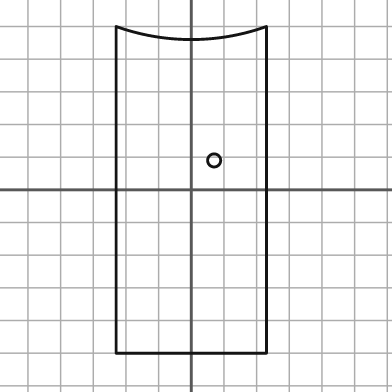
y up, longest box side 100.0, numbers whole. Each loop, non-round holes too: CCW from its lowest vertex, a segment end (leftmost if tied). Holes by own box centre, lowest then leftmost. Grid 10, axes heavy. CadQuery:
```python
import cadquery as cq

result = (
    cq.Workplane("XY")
    .moveTo(-23.0, -50.0)
    .lineTo(23.0, -50.0)
    .lineTo(23.0, 50.0)
    .threePointArc((0.0, 46.0), (-23.0, 50.0))
    .close()
    .moveTo(7.0, 9.0)
    .circle(2.0)
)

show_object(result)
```